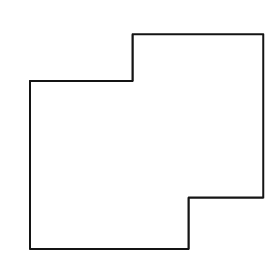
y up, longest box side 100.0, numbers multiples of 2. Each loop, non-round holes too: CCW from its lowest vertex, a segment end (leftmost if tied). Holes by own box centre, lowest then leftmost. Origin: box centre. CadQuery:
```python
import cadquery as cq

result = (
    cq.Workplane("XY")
    .moveTo(-50.0, -46.0)
    .lineTo(18.0, -46.0)
    .lineTo(18.0, -24.0)
    .lineTo(50.0, -24.0)
    .lineTo(50.0, 46.0)
    .lineTo(-6.0, 46.0)
    .lineTo(-6.0, 26.0)
    .lineTo(-50.0, 26.0)
    .close()
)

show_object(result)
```